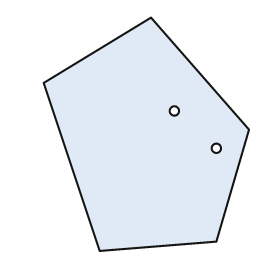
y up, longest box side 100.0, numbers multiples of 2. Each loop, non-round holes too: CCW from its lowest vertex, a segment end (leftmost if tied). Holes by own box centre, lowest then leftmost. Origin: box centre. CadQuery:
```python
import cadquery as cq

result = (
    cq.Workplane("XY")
    .moveTo(-20.0, -50.0)
    .lineTo(30.0, -46.0)
    .lineTo(44.0, 2.0)
    .lineTo(2.0, 50.0)
    .lineTo(-44.0, 22.0)
    .close()
    .moveTo(30.0, -6.0)
    .circle(2.0)
    .moveTo(12.0, 10.0)
    .circle(2.0)
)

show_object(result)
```